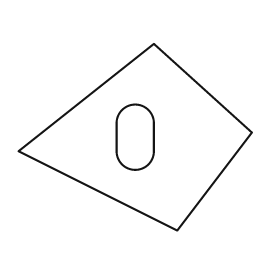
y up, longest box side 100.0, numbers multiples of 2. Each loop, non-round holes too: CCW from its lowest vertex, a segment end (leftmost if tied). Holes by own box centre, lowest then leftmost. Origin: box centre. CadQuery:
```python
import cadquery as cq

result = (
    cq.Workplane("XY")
    .moveTo(18.0, -40.0)
    .lineTo(50.0, 2.0)
    .lineTo(8.0, 40.0)
    .lineTo(-50.0, -6.0)
    .close()
    .moveTo(-8.0, -6.0)
    .threePointArc((0.0, -14.0), (8.0, -6.0))
    .lineTo(8.0, 6.0)
    .threePointArc((0.0, 14.0), (-8.0, 6.0))
    .close()
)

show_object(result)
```